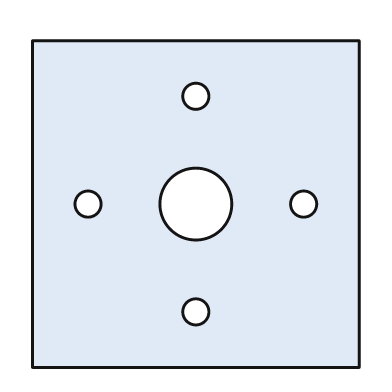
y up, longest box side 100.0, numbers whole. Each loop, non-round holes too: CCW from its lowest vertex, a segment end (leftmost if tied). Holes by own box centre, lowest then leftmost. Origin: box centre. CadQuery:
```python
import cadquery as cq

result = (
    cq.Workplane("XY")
    .moveTo(-50.0, -50.0)
    .lineTo(50.0, -50.0)
    .lineTo(50.0, 50.0)
    .lineTo(-50.0, 50.0)
    .close()
    .moveTo(0.0, -33.0)
    .circle(4.0)
    .moveTo(-33.0, 0.0)
    .circle(4.0)
    .moveTo(0.0, 0.0)
    .circle(11.0)
    .moveTo(33.0, 0.0)
    .circle(4.0)
    .moveTo(0.0, 33.0)
    .circle(4.0)
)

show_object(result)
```